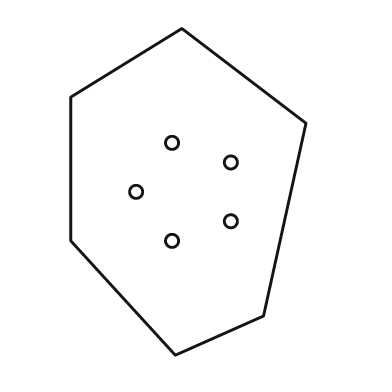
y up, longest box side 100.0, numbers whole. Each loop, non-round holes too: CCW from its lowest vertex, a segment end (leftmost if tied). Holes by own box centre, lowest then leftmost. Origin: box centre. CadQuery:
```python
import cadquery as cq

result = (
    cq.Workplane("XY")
    .moveTo(-4.0, -50.0)
    .lineTo(23.0, -38.0)
    .lineTo(36.0, 21.0)
    .lineTo(-2.0, 50.0)
    .lineTo(-36.0, 29.0)
    .lineTo(-36.0, -15.0)
    .close()
    .moveTo(-5.0, -15.0)
    .circle(2.0)
    .moveTo(13.0, -9.0)
    .circle(2.0)
    .moveTo(-16.0, 0.0)
    .circle(2.0)
    .moveTo(13.0, 9.0)
    .circle(2.0)
    .moveTo(-5.0, 15.0)
    .circle(2.0)
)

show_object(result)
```